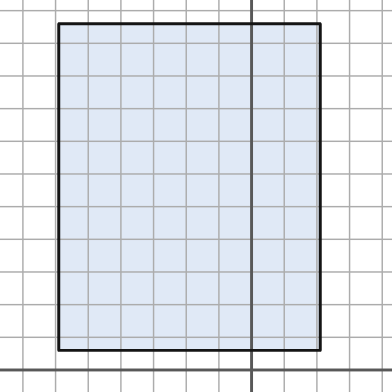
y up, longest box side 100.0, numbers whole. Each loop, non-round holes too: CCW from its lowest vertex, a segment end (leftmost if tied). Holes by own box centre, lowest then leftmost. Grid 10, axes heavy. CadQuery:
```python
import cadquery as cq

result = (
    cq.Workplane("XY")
    .moveTo(-59.0, 6.0)
    .lineTo(21.0, 6.0)
    .lineTo(21.0, 106.0)
    .lineTo(-59.0, 106.0)
    .close()
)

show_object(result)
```